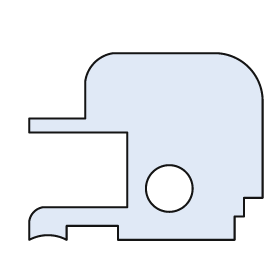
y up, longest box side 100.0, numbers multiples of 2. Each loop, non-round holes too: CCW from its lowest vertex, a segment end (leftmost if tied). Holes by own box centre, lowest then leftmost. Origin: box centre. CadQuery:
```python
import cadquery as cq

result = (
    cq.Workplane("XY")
    .moveTo(-50.0, -40.0)
    .threePointArc((-42.0, -38.0), (-34.0, -40.0))
    .lineTo(-34.0, -34.0)
    .lineTo(-12.0, -34.0)
    .lineTo(-12.0, -40.0)
    .lineTo(38.0, -40.0)
    .lineTo(38.0, -30.0)
    .lineTo(42.0, -30.0)
    .lineTo(42.0, -22.0)
    .lineTo(50.0, -22.0)
    .lineTo(50.0, 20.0)
    .threePointArc((44.0, 34.0), (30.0, 40.0))
    .lineTo(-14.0, 40.0)
    .threePointArc((-22.0, 36.0), (-26.0, 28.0))
    .lineTo(-26.0, 12.0)
    .lineTo(-50.0, 12.0)
    .lineTo(-50.0, 6.0)
    .lineTo(-8.0, 6.0)
    .lineTo(-8.0, -26.0)
    .lineTo(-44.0, -26.0)
    .threePointArc((-48.0, -28.0), (-50.0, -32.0))
    .close()
    .moveTo(10.0, -18.0)
    .circle(10.0)
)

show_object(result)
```